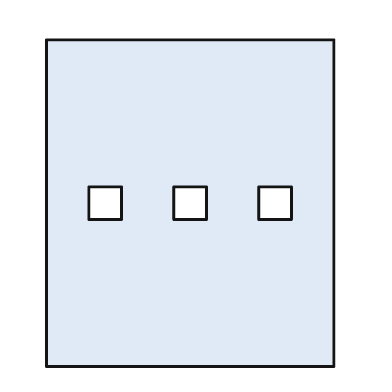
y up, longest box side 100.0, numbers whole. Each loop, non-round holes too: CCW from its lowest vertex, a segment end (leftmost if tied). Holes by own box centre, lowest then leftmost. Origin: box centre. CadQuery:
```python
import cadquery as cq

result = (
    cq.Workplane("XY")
    .moveTo(-44.0, -50.0)
    .lineTo(44.0, -50.0)
    .lineTo(44.0, 50.0)
    .lineTo(-44.0, 50.0)
    .close()
    .moveTo(-31.0, -5.0)
    .lineTo(-21.0, -5.0)
    .lineTo(-21.0, 5.0)
    .lineTo(-31.0, 5.0)
    .close()
    .moveTo(-5.0, -5.0)
    .lineTo(5.0, -5.0)
    .lineTo(5.0, 5.0)
    .lineTo(-5.0, 5.0)
    .close()
    .moveTo(21.0, -5.0)
    .lineTo(31.0, -5.0)
    .lineTo(31.0, 5.0)
    .lineTo(21.0, 5.0)
    .close()
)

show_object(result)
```